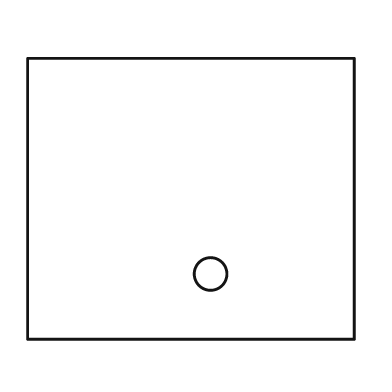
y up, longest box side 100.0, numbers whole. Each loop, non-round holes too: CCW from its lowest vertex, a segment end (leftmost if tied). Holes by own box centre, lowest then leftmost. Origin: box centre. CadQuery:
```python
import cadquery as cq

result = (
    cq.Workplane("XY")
    .moveTo(-50.0, -43.0)
    .lineTo(50.0, -43.0)
    .lineTo(50.0, 43.0)
    .lineTo(-50.0, 43.0)
    .close()
    .moveTo(6.0, -23.0)
    .circle(5.0)
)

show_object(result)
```